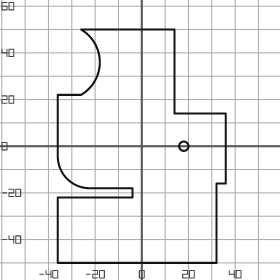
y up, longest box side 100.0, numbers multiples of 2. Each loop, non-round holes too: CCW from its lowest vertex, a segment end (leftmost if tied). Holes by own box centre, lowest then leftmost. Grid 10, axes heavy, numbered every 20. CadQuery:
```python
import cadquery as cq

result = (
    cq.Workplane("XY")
    .moveTo(-36.0, -50.0)
    .lineTo(32.0, -50.0)
    .lineTo(32.0, -16.0)
    .lineTo(36.0, -16.0)
    .lineTo(36.0, 14.0)
    .lineTo(14.0, 14.0)
    .lineTo(14.0, 50.0)
    .lineTo(-26.0, 50.0)
    .threePointArc((-18.0, 36.0), (-26.0, 22.0))
    .lineTo(-36.0, 22.0)
    .lineTo(-36.0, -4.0)
    .threePointArc((-32.0, -14.0), (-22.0, -18.0))
    .lineTo(-4.0, -18.0)
    .lineTo(-4.0, -22.0)
    .lineTo(-36.0, -22.0)
    .close()
    .moveTo(18.0, 0.0)
    .circle(2.0)
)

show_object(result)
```